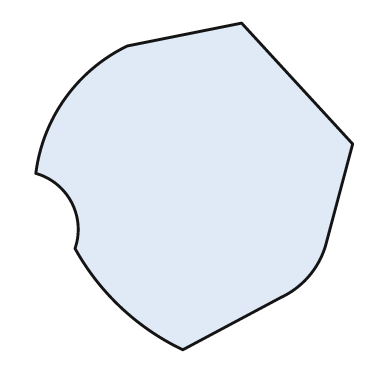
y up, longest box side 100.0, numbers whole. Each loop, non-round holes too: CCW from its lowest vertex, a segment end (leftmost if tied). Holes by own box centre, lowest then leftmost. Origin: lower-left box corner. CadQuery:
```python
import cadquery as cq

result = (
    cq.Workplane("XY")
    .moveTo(45.0, 0.0)
    .lineTo(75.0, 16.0)
    .threePointArc((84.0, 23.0), (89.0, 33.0))
    .lineTo(97.0, 63.0)
    .lineTo(63.0, 100.0)
    .lineTo(28.0, 93.0)
    .threePointArc((9.0, 77.0), (0.0, 54.0))
    .threePointArc((11.0, 45.0), (12.0, 31.0))
    .threePointArc((26.0, 13.0), (45.0, 0.0))
    .close()
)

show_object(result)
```